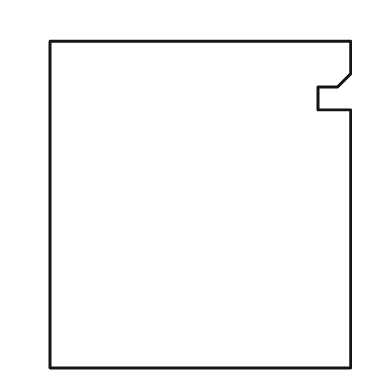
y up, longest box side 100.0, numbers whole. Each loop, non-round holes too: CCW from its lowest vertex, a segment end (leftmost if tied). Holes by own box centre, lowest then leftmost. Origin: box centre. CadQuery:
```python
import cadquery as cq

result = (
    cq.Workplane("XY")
    .moveTo(-46.0, -50.0)
    .lineTo(46.0, -50.0)
    .lineTo(46.0, 29.0)
    .lineTo(36.0, 29.0)
    .lineTo(36.0, 36.0)
    .lineTo(42.0, 36.0)
    .lineTo(46.0, 40.0)
    .lineTo(46.0, 50.0)
    .lineTo(-46.0, 50.0)
    .close()
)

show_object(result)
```